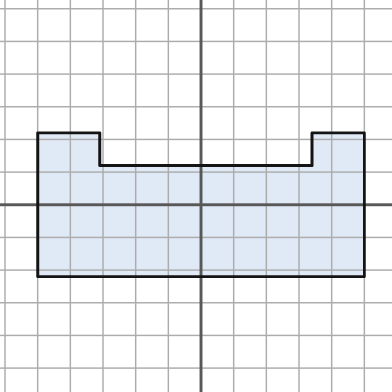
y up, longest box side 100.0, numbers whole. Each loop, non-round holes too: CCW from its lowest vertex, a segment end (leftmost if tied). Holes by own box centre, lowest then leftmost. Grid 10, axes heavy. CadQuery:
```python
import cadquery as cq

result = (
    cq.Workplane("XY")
    .moveTo(-50.0, -22.0)
    .lineTo(50.0, -22.0)
    .lineTo(50.0, 22.0)
    .lineTo(34.0, 22.0)
    .lineTo(34.0, 12.0)
    .lineTo(-31.0, 12.0)
    .lineTo(-31.0, 22.0)
    .lineTo(-50.0, 22.0)
    .close()
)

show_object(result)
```